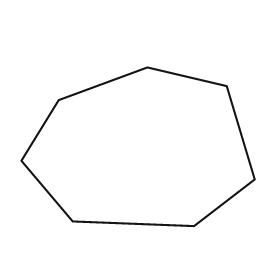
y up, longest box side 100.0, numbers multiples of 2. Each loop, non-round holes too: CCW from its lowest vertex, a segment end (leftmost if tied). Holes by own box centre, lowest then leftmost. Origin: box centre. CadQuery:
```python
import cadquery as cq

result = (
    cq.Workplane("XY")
    .moveTo(24.0, -34.0)
    .lineTo(50.0, -14.0)
    .lineTo(38.0, 26.0)
    .lineTo(4.0, 34.0)
    .lineTo(-34.0, 20.0)
    .lineTo(-50.0, -6.0)
    .lineTo(-28.0, -32.0)
    .close()
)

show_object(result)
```